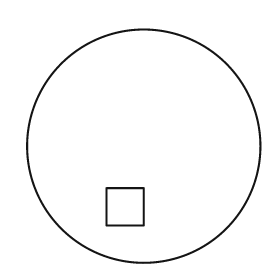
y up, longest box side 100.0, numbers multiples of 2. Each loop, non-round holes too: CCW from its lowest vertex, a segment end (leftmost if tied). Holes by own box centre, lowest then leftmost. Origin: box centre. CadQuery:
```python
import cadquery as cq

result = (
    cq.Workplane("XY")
    .moveTo(0.0, 0.0)
    .circle(50.0)
    .moveTo(-16.0, -34.0)
    .lineTo(0.0, -34.0)
    .lineTo(0.0, -18.0)
    .lineTo(-16.0, -18.0)
    .close()
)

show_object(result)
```